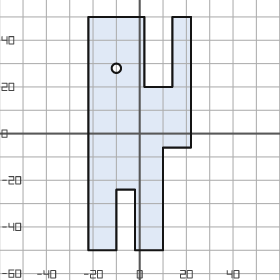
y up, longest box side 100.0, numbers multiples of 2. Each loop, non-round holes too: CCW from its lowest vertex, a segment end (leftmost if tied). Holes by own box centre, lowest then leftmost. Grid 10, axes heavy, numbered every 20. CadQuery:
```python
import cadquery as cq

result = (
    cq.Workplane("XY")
    .moveTo(-22.0, -50.0)
    .lineTo(-10.0, -50.0)
    .lineTo(-10.0, -24.0)
    .lineTo(-2.0, -24.0)
    .lineTo(-2.0, -50.0)
    .lineTo(10.0, -50.0)
    .lineTo(10.0, -6.0)
    .lineTo(22.0, -6.0)
    .lineTo(22.0, 50.0)
    .lineTo(14.0, 50.0)
    .lineTo(14.0, 20.0)
    .lineTo(2.0, 20.0)
    .lineTo(2.0, 50.0)
    .lineTo(-22.0, 50.0)
    .close()
    .moveTo(-10.0, 28.0)
    .circle(2.0)
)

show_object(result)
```